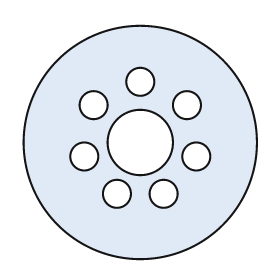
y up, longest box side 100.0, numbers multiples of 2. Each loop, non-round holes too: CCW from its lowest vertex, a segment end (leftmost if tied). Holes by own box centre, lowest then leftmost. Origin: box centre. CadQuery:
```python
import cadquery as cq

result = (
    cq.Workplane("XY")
    .moveTo(0.0, 0.0)
    .circle(50.0)
    .moveTo(-10.0, -22.0)
    .circle(6.0)
    .moveTo(10.0, -22.0)
    .circle(6.0)
    .moveTo(-24.0, -6.0)
    .circle(6.0)
    .moveTo(24.0, -6.0)
    .circle(6.0)
    .moveTo(0.0, 0.0)
    .circle(14.0)
    .moveTo(-20.0, 16.0)
    .circle(6.0)
    .moveTo(20.0, 16.0)
    .circle(6.0)
    .moveTo(0.0, 26.0)
    .circle(6.0)
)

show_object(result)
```